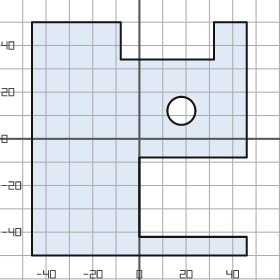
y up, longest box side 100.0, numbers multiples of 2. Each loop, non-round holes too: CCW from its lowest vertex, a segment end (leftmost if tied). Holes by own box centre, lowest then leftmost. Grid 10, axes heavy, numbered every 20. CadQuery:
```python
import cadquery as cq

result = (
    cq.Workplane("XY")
    .moveTo(-46.0, -50.0)
    .lineTo(46.0, -50.0)
    .lineTo(46.0, -42.0)
    .lineTo(0.0, -42.0)
    .lineTo(0.0, -8.0)
    .lineTo(46.0, -8.0)
    .lineTo(46.0, 50.0)
    .lineTo(32.0, 50.0)
    .lineTo(32.0, 34.0)
    .lineTo(-8.0, 34.0)
    .lineTo(-8.0, 50.0)
    .lineTo(-46.0, 50.0)
    .close()
    .moveTo(18.0, 12.0)
    .circle(6.0)
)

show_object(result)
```